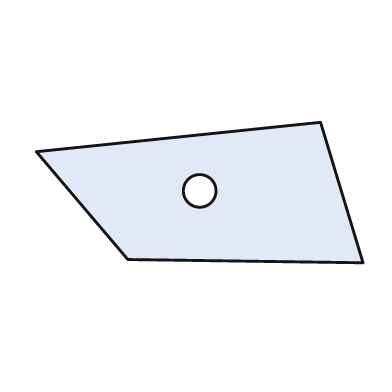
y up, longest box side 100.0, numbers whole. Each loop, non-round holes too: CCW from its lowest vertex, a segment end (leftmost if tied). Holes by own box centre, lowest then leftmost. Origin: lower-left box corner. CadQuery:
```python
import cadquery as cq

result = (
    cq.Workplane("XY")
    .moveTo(100.0, 0.0)
    .lineTo(87.0, 43.0)
    .lineTo(0.0, 34.0)
    .lineTo(28.0, 1.0)
    .close()
    .moveTo(50.0, 22.0)
    .circle(5.0)
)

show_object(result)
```